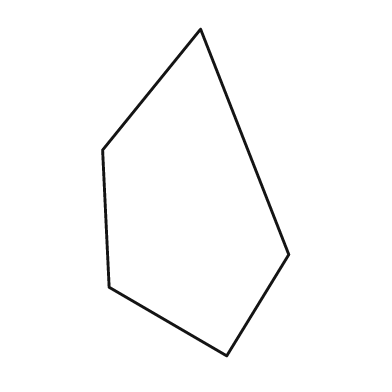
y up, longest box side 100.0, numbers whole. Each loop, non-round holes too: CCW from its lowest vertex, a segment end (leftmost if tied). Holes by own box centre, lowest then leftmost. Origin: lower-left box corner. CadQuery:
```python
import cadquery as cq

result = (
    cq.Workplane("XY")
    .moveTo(38.0, 0.0)
    .lineTo(57.0, 31.0)
    .lineTo(30.0, 100.0)
    .lineTo(0.0, 63.0)
    .lineTo(2.0, 21.0)
    .close()
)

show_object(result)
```